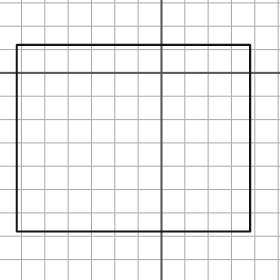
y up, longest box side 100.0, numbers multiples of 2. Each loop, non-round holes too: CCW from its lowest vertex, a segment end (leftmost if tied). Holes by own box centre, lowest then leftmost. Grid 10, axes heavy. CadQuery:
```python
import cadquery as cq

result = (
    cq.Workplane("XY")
    .moveTo(-62.0, -68.0)
    .lineTo(38.0, -68.0)
    .lineTo(38.0, 12.0)
    .lineTo(-62.0, 12.0)
    .close()
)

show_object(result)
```